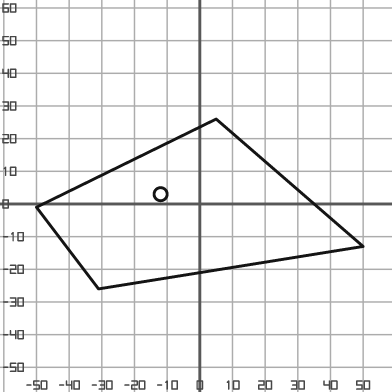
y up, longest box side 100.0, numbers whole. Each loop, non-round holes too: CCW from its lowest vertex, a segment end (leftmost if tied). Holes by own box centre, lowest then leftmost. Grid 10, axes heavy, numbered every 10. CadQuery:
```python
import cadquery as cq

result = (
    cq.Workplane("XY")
    .moveTo(-31.0, -26.0)
    .lineTo(50.0, -13.0)
    .lineTo(5.0, 26.0)
    .lineTo(-50.0, -1.0)
    .close()
    .moveTo(-12.0, 3.0)
    .circle(2.0)
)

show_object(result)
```